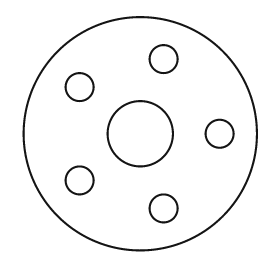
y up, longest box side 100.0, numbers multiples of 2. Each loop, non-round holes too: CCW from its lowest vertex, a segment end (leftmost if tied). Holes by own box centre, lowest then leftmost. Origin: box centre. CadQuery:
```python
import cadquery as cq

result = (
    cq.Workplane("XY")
    .moveTo(0.0, 0.0)
    .circle(50.0)
    .moveTo(10.0, -32.0)
    .circle(6.0)
    .moveTo(-26.0, -20.0)
    .circle(6.0)
    .moveTo(0.0, 0.0)
    .circle(14.0)
    .moveTo(34.0, 0.0)
    .circle(6.0)
    .moveTo(-26.0, 20.0)
    .circle(6.0)
    .moveTo(10.0, 32.0)
    .circle(6.0)
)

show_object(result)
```